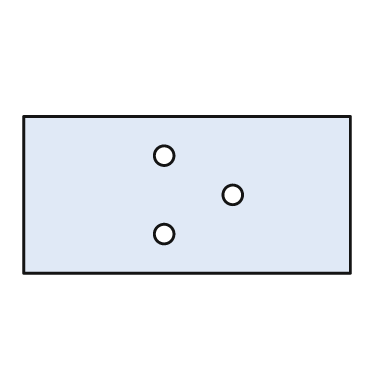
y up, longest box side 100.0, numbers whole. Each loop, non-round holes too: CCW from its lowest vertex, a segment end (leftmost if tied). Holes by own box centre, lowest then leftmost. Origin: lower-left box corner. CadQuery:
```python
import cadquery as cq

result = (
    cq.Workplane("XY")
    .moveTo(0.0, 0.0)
    .lineTo(100.0, 0.0)
    .lineTo(100.0, 48.0)
    .lineTo(0.0, 48.0)
    .close()
    .moveTo(43.0, 12.0)
    .circle(3.0)
    .moveTo(64.0, 24.0)
    .circle(3.0)
    .moveTo(43.0, 36.0)
    .circle(3.0)
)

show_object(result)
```